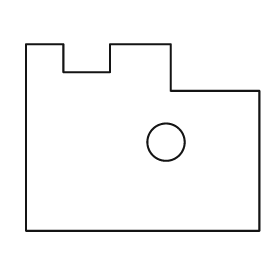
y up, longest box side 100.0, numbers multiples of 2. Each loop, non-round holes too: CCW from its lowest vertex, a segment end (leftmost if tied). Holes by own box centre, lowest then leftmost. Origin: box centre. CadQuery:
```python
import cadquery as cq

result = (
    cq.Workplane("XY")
    .moveTo(-50.0, -40.0)
    .lineTo(50.0, -40.0)
    .lineTo(50.0, 20.0)
    .lineTo(12.0, 20.0)
    .lineTo(12.0, 40.0)
    .lineTo(-14.0, 40.0)
    .lineTo(-14.0, 28.0)
    .lineTo(-34.0, 28.0)
    .lineTo(-34.0, 40.0)
    .lineTo(-50.0, 40.0)
    .close()
    .moveTo(10.0, -2.0)
    .circle(8.0)
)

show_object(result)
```